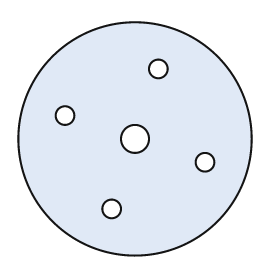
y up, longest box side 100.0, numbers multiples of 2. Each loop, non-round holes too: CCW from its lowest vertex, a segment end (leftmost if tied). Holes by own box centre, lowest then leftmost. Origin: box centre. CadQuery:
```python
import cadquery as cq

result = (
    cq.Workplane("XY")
    .moveTo(0.0, 0.0)
    .circle(50.0)
    .moveTo(-10.0, -30.0)
    .circle(4.0)
    .moveTo(30.0, -10.0)
    .circle(4.0)
    .moveTo(0.0, 0.0)
    .circle(6.0)
    .moveTo(-30.0, 10.0)
    .circle(4.0)
    .moveTo(10.0, 30.0)
    .circle(4.0)
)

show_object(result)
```